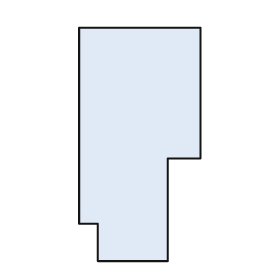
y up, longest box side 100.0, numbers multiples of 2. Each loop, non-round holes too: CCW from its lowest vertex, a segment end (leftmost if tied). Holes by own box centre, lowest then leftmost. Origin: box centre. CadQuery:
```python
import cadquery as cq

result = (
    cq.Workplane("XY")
    .moveTo(-18.0, -50.0)
    .lineTo(12.0, -50.0)
    .lineTo(12.0, -6.0)
    .lineTo(26.0, -6.0)
    .lineTo(26.0, 50.0)
    .lineTo(-26.0, 50.0)
    .lineTo(-26.0, -34.0)
    .lineTo(-18.0, -34.0)
    .close()
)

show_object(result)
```